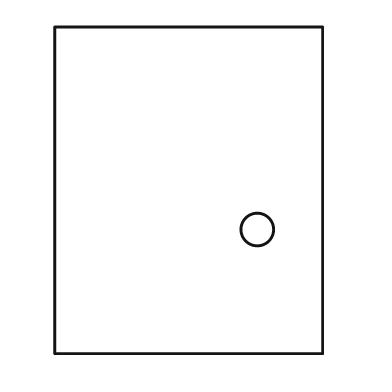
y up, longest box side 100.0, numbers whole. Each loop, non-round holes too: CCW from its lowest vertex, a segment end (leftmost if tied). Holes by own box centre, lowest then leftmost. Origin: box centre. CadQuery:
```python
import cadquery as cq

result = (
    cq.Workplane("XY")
    .moveTo(-41.0, -50.0)
    .lineTo(41.0, -50.0)
    .lineTo(41.0, 50.0)
    .lineTo(-41.0, 50.0)
    .close()
    .moveTo(21.0, -12.0)
    .circle(5.0)
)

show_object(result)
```